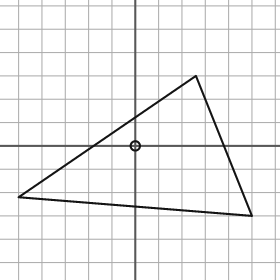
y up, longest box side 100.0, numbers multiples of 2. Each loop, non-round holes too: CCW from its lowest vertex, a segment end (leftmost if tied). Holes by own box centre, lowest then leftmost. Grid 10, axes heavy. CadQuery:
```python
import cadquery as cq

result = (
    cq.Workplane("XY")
    .moveTo(50.0, -30.0)
    .lineTo(26.0, 30.0)
    .lineTo(-50.0, -22.0)
    .close()
    .moveTo(0.0, 0.0)
    .circle(2.0)
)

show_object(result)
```